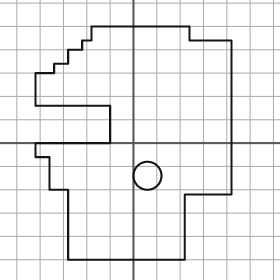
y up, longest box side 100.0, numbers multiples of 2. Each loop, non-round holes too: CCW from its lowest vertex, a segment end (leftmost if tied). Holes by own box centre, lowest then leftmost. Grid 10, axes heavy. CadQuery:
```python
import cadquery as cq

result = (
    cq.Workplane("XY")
    .moveTo(-28.0, -50.0)
    .lineTo(22.0, -50.0)
    .lineTo(22.0, -22.0)
    .lineTo(42.0, -22.0)
    .lineTo(42.0, 44.0)
    .lineTo(24.0, 44.0)
    .lineTo(24.0, 50.0)
    .lineTo(-18.0, 50.0)
    .lineTo(-18.0, 44.0)
    .lineTo(-22.0, 44.0)
    .lineTo(-22.0, 40.0)
    .lineTo(-28.0, 40.0)
    .lineTo(-28.0, 34.0)
    .lineTo(-34.0, 34.0)
    .lineTo(-34.0, 30.0)
    .lineTo(-42.0, 30.0)
    .lineTo(-42.0, 16.0)
    .lineTo(-10.0, 16.0)
    .lineTo(-10.0, 0.0)
    .lineTo(-42.0, 0.0)
    .lineTo(-42.0, -6.0)
    .lineTo(-36.0, -6.0)
    .lineTo(-36.0, -20.0)
    .lineTo(-28.0, -20.0)
    .close()
    .moveTo(6.0, -14.0)
    .circle(6.0)
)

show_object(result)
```